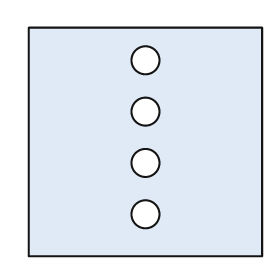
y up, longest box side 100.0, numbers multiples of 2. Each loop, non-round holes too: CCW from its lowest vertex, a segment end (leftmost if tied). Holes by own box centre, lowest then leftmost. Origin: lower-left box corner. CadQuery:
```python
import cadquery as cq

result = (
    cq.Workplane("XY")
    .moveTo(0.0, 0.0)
    .lineTo(100.0, 0.0)
    .lineTo(100.0, 98.0)
    .lineTo(0.0, 98.0)
    .close()
    .moveTo(50.0, 18.0)
    .circle(6.0)
    .moveTo(50.0, 40.0)
    .circle(6.0)
    .moveTo(50.0, 62.0)
    .circle(6.0)
    .moveTo(50.0, 84.0)
    .circle(6.0)
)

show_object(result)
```